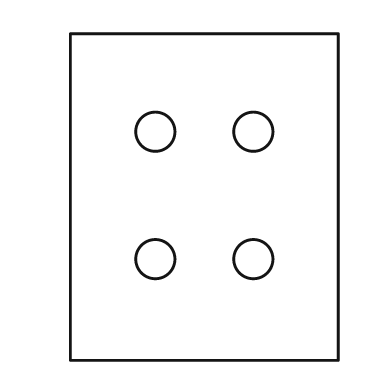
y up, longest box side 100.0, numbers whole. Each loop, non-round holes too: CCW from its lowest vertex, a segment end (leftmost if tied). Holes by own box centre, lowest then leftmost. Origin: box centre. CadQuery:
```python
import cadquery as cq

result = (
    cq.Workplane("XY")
    .moveTo(-41.0, -50.0)
    .lineTo(41.0, -50.0)
    .lineTo(41.0, 50.0)
    .lineTo(-41.0, 50.0)
    .close()
    .moveTo(-15.0, -19.0)
    .circle(6.0)
    .moveTo(15.0, -19.0)
    .circle(6.0)
    .moveTo(-15.0, 20.0)
    .circle(6.0)
    .moveTo(15.0, 20.0)
    .circle(6.0)
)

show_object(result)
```